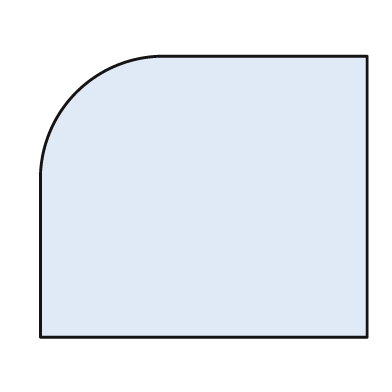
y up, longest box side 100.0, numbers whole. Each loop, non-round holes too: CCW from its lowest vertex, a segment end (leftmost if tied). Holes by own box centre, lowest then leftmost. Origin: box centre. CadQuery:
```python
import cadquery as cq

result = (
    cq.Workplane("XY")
    .moveTo(-50.0, -43.0)
    .lineTo(50.0, -43.0)
    .lineTo(50.0, 43.0)
    .lineTo(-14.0, 43.0)
    .threePointArc((-39.0, 32.0), (-50.0, 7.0))
    .close()
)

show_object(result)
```